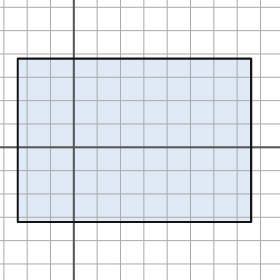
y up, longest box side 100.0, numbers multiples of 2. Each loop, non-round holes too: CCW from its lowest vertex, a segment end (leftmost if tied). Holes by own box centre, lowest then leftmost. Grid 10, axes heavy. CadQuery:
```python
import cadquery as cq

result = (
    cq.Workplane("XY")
    .moveTo(-24.0, -32.0)
    .lineTo(76.0, -32.0)
    .lineTo(76.0, 38.0)
    .lineTo(-24.0, 38.0)
    .close()
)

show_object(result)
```